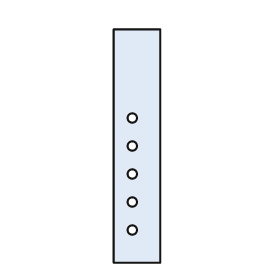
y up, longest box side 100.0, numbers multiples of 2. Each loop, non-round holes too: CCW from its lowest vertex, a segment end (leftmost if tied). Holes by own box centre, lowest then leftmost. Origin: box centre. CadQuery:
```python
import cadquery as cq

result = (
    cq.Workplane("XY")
    .moveTo(-10.0, -50.0)
    .lineTo(10.0, -50.0)
    .lineTo(10.0, 50.0)
    .lineTo(-10.0, 50.0)
    .close()
    .moveTo(-2.0, -36.0)
    .circle(2.0)
    .moveTo(-2.0, -24.0)
    .circle(2.0)
    .moveTo(-2.0, -12.0)
    .circle(2.0)
    .moveTo(-2.0, 0.0)
    .circle(2.0)
    .moveTo(-2.0, 12.0)
    .circle(2.0)
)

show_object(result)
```